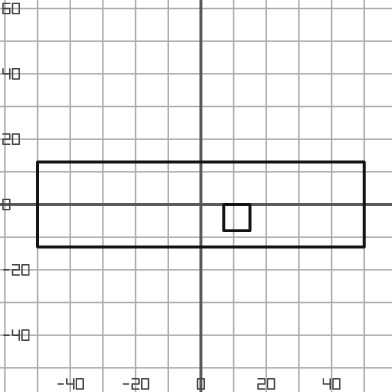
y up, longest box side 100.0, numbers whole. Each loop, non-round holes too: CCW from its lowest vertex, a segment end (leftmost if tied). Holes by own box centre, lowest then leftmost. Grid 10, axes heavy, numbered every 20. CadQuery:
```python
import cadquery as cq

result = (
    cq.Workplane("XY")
    .moveTo(-50.0, -13.0)
    .lineTo(50.0, -13.0)
    .lineTo(50.0, 13.0)
    .lineTo(-50.0, 13.0)
    .close()
    .moveTo(7.0, -8.0)
    .lineTo(15.0, -8.0)
    .lineTo(15.0, 0.0)
    .lineTo(7.0, 0.0)
    .close()
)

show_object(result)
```